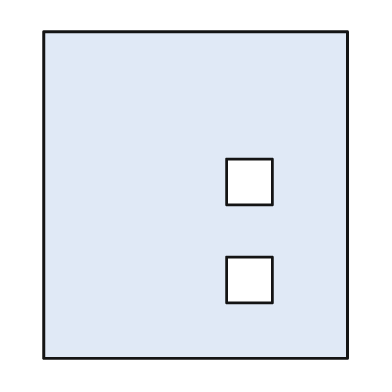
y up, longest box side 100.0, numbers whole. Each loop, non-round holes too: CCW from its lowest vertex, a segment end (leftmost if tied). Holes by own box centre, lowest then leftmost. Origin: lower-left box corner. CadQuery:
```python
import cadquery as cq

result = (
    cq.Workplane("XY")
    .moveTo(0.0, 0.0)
    .lineTo(93.0, 0.0)
    .lineTo(93.0, 100.0)
    .lineTo(0.0, 100.0)
    .close()
    .moveTo(56.0, 17.0)
    .lineTo(70.0, 17.0)
    .lineTo(70.0, 31.0)
    .lineTo(56.0, 31.0)
    .close()
    .moveTo(56.0, 47.0)
    .lineTo(70.0, 47.0)
    .lineTo(70.0, 61.0)
    .lineTo(56.0, 61.0)
    .close()
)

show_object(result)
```